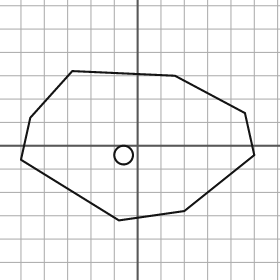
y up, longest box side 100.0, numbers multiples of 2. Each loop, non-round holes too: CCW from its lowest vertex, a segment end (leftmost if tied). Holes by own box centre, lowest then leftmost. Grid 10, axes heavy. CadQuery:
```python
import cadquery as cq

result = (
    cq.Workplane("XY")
    .moveTo(-8.0, -32.0)
    .lineTo(20.0, -28.0)
    .lineTo(50.0, -4.0)
    .lineTo(46.0, 14.0)
    .lineTo(16.0, 30.0)
    .lineTo(-28.0, 32.0)
    .lineTo(-46.0, 12.0)
    .lineTo(-50.0, -6.0)
    .close()
    .moveTo(-6.0, -4.0)
    .circle(4.0)
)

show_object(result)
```